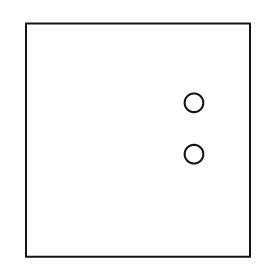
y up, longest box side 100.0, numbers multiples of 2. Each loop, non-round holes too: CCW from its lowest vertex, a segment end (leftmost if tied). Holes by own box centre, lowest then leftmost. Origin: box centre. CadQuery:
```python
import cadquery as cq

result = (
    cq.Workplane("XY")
    .moveTo(-48.0, -50.0)
    .lineTo(48.0, -50.0)
    .lineTo(48.0, 50.0)
    .lineTo(-48.0, 50.0)
    .close()
    .moveTo(24.0, -6.0)
    .circle(4.0)
    .moveTo(24.0, 16.0)
    .circle(4.0)
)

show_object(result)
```